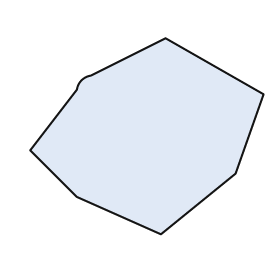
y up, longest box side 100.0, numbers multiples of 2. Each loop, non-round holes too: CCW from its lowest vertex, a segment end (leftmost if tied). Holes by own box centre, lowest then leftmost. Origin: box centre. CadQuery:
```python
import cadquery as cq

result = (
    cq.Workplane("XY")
    .moveTo(6.0, -42.0)
    .lineTo(38.0, -16.0)
    .lineTo(50.0, 18.0)
    .lineTo(8.0, 42.0)
    .lineTo(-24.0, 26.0)
    .threePointArc((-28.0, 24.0), (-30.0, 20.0))
    .lineTo(-50.0, -6.0)
    .lineTo(-30.0, -26.0)
    .close()
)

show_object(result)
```